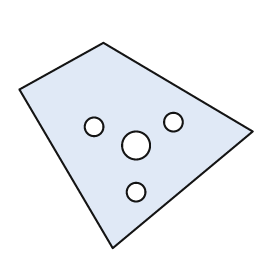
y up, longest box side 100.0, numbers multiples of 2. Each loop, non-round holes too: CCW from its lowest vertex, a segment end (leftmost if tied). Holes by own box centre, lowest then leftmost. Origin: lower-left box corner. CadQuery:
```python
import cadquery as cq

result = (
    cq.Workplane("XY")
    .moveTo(40.0, 0.0)
    .lineTo(100.0, 50.0)
    .lineTo(36.0, 88.0)
    .lineTo(0.0, 68.0)
    .close()
    .moveTo(50.0, 24.0)
    .circle(4.0)
    .moveTo(50.0, 44.0)
    .circle(6.0)
    .moveTo(32.0, 52.0)
    .circle(4.0)
    .moveTo(66.0, 54.0)
    .circle(4.0)
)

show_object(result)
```